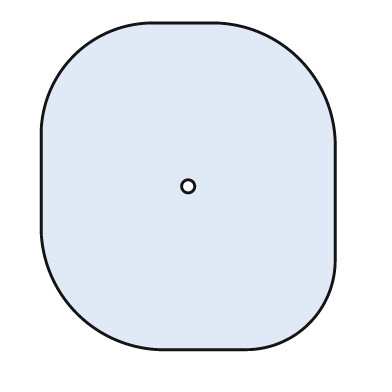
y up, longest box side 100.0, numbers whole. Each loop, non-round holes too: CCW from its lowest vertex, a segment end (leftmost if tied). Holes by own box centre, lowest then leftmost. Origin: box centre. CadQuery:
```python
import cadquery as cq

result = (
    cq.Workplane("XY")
    .moveTo(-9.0, -50.0)
    .lineTo(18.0, -50.0)
    .threePointArc((37.0, -42.0), (45.0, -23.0))
    .lineTo(45.0, 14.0)
    .threePointArc((34.0, 39.0), (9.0, 50.0))
    .lineTo(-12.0, 50.0)
    .threePointArc((-35.0, 40.0), (-45.0, 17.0))
    .lineTo(-45.0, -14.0)
    .threePointArc((-34.0, -39.0), (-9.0, -50.0))
    .close()
    .moveTo(0.0, 0.0)
    .circle(2.0)
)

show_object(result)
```